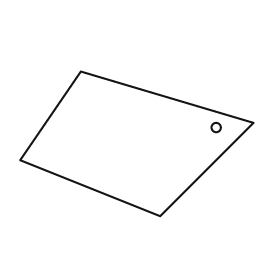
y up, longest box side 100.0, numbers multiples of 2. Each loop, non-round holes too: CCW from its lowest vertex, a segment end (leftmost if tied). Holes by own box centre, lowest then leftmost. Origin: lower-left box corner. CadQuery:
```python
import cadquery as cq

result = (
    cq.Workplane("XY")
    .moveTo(60.0, 0.0)
    .lineTo(100.0, 40.0)
    .lineTo(26.0, 62.0)
    .lineTo(0.0, 24.0)
    .close()
    .moveTo(84.0, 38.0)
    .circle(2.0)
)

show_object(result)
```